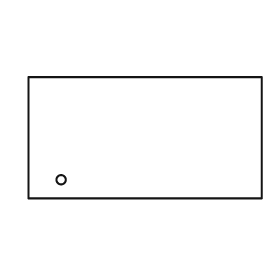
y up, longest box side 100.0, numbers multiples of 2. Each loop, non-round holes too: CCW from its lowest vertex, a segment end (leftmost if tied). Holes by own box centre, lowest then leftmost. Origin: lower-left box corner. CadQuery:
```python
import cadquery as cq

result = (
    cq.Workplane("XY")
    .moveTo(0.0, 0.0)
    .lineTo(100.0, 0.0)
    .lineTo(100.0, 52.0)
    .lineTo(0.0, 52.0)
    .close()
    .moveTo(14.0, 8.0)
    .circle(2.0)
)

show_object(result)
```